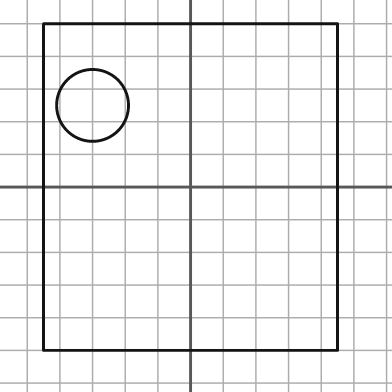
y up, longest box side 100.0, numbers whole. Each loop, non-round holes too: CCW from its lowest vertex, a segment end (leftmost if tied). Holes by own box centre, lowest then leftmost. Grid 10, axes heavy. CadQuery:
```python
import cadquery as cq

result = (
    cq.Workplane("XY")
    .moveTo(-45.0, -50.0)
    .lineTo(45.0, -50.0)
    .lineTo(45.0, 50.0)
    .lineTo(-45.0, 50.0)
    .close()
    .moveTo(-30.0, 25.0)
    .circle(11.0)
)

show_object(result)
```